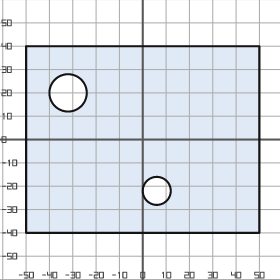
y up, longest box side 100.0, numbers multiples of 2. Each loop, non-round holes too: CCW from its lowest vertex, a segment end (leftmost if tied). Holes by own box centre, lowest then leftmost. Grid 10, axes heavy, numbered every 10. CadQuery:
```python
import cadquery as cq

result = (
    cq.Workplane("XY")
    .moveTo(-50.0, -40.0)
    .lineTo(50.0, -40.0)
    .lineTo(50.0, 40.0)
    .lineTo(-50.0, 40.0)
    .close()
    .moveTo(6.0, -22.0)
    .circle(6.0)
    .moveTo(-32.0, 20.0)
    .circle(8.0)
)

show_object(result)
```